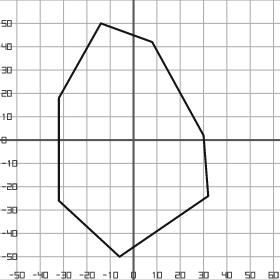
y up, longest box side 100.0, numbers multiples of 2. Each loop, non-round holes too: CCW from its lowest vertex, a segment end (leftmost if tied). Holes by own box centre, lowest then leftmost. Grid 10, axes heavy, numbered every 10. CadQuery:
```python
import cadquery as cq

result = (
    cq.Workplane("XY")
    .moveTo(-6.0, -50.0)
    .lineTo(32.0, -24.0)
    .lineTo(30.0, 2.0)
    .lineTo(8.0, 42.0)
    .lineTo(-14.0, 50.0)
    .lineTo(-32.0, 18.0)
    .lineTo(-32.0, -26.0)
    .close()
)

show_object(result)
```